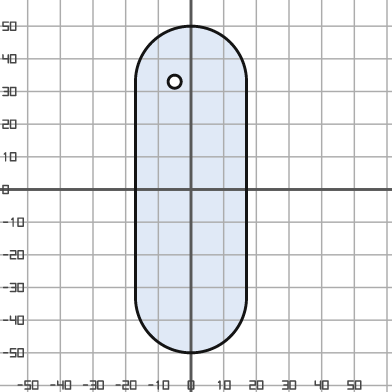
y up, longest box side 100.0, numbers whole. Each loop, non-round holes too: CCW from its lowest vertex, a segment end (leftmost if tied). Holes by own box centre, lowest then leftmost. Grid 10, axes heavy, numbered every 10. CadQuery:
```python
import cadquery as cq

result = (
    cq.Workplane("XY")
    .moveTo(-17.0, -33.0)
    .threePointArc((0.0, -50.0), (17.0, -33.0))
    .lineTo(17.0, 33.0)
    .threePointArc((0.0, 50.0), (-17.0, 33.0))
    .close()
    .moveTo(-5.0, 33.0)
    .circle(2.0)
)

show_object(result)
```